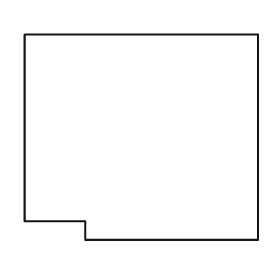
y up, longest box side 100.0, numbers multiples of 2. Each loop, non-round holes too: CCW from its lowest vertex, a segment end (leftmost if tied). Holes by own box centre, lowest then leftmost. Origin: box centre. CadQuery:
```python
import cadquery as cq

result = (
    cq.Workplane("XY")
    .moveTo(-24.0, -44.0)
    .lineTo(50.0, -44.0)
    .lineTo(50.0, 44.0)
    .lineTo(-50.0, 44.0)
    .lineTo(-50.0, -36.0)
    .lineTo(-24.0, -36.0)
    .close()
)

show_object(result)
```